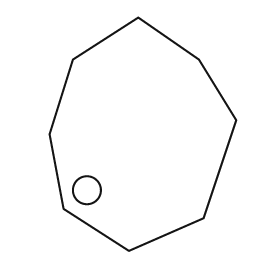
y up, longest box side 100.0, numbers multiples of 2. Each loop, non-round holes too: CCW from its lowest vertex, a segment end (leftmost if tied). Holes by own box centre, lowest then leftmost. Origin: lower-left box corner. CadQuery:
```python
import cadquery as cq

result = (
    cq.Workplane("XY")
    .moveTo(34.0, 0.0)
    .lineTo(66.0, 14.0)
    .lineTo(80.0, 56.0)
    .lineTo(64.0, 82.0)
    .lineTo(38.0, 100.0)
    .lineTo(10.0, 82.0)
    .lineTo(0.0, 50.0)
    .lineTo(6.0, 18.0)
    .close()
    .moveTo(16.0, 26.0)
    .circle(6.0)
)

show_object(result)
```